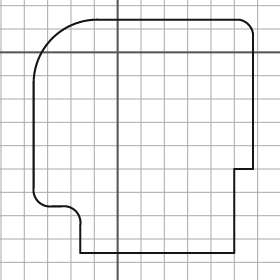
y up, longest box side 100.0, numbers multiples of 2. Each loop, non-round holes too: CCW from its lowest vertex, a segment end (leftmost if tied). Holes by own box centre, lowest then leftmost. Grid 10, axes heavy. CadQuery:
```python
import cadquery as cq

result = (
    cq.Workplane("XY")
    .moveTo(-16.0, -86.0)
    .lineTo(50.0, -86.0)
    .lineTo(50.0, -50.0)
    .lineTo(58.0, -50.0)
    .lineTo(58.0, 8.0)
    .threePointArc((56.0, 12.0), (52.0, 14.0))
    .lineTo(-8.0, 14.0)
    .threePointArc((-28.0, 6.0), (-36.0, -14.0))
    .lineTo(-36.0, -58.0)
    .threePointArc((-34.0, -64.0), (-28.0, -66.0))
    .lineTo(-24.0, -66.0)
    .threePointArc((-18.0, -68.0), (-16.0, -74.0))
    .close()
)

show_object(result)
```